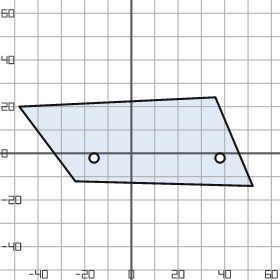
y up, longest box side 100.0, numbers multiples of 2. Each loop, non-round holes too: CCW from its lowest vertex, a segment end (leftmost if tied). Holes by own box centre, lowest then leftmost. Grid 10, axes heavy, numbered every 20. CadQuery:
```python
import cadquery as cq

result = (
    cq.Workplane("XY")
    .moveTo(52.0, -14.0)
    .lineTo(36.0, 24.0)
    .lineTo(-48.0, 20.0)
    .lineTo(-24.0, -12.0)
    .close()
    .moveTo(-16.0, -2.0)
    .circle(2.0)
    .moveTo(38.0, -2.0)
    .circle(2.0)
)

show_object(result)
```